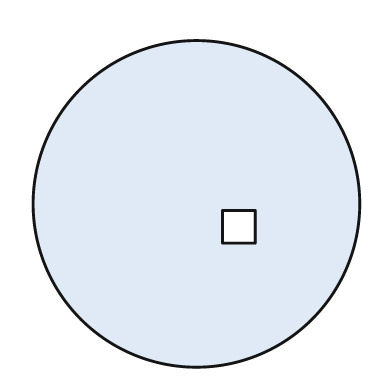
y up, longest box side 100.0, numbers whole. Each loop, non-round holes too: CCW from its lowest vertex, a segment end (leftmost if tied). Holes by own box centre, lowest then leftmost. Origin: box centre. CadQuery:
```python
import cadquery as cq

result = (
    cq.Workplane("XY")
    .moveTo(0.0, 0.0)
    .circle(50.0)
    .moveTo(8.0, -12.0)
    .lineTo(18.0, -12.0)
    .lineTo(18.0, -2.0)
    .lineTo(8.0, -2.0)
    .close()
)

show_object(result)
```